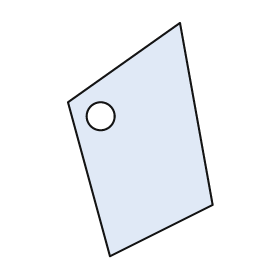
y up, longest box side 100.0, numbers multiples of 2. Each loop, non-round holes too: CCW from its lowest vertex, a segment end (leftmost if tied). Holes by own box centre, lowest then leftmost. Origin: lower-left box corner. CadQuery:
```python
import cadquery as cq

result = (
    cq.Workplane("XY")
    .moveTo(18.0, 0.0)
    .lineTo(62.0, 22.0)
    .lineTo(48.0, 100.0)
    .lineTo(0.0, 66.0)
    .close()
    .moveTo(14.0, 60.0)
    .circle(6.0)
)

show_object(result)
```